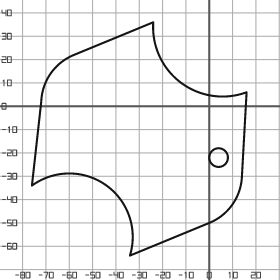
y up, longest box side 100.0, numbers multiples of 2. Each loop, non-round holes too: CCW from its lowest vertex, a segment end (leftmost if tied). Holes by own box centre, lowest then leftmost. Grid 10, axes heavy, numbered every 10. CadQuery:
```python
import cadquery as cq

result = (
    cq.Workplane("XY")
    .moveTo(-34.0, -64.0)
    .lineTo(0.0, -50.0)
    .threePointArc((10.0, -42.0), (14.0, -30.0))
    .lineTo(16.0, 6.0)
    .threePointArc((-12.0, 10.0), (-24.0, 36.0))
    .lineTo(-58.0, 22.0)
    .threePointArc((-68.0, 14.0), (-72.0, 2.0))
    .lineTo(-76.0, -34.0)
    .threePointArc((-44.0, -34.0), (-34.0, -64.0))
    .close()
    .moveTo(4.0, -22.0)
    .circle(4.0)
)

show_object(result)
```